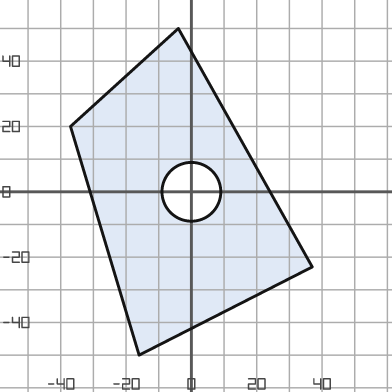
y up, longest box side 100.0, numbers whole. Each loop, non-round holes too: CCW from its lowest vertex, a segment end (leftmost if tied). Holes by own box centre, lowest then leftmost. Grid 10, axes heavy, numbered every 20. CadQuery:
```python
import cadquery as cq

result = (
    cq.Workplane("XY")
    .moveTo(-16.0, -50.0)
    .lineTo(37.0, -23.0)
    .lineTo(-4.0, 50.0)
    .lineTo(-37.0, 20.0)
    .close()
    .moveTo(0.0, 0.0)
    .circle(9.0)
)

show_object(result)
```